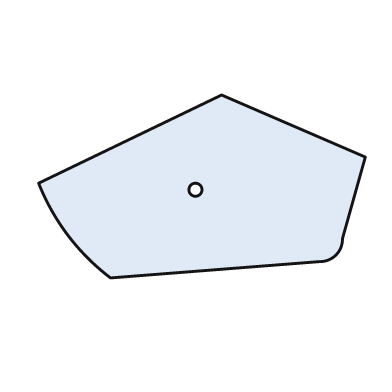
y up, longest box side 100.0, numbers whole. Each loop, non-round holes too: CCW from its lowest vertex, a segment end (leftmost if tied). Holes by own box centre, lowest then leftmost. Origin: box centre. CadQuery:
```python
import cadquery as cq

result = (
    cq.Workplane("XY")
    .moveTo(-28.0, -28.0)
    .lineTo(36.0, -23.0)
    .threePointArc((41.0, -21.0), (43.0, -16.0))
    .lineTo(50.0, 9.0)
    .lineTo(6.0, 28.0)
    .lineTo(-50.0, 1.0)
    .threePointArc((-41.0, -15.0), (-28.0, -28.0))
    .close()
    .moveTo(-2.0, -1.0)
    .circle(2.0)
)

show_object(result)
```